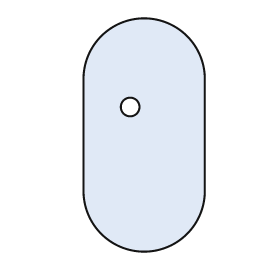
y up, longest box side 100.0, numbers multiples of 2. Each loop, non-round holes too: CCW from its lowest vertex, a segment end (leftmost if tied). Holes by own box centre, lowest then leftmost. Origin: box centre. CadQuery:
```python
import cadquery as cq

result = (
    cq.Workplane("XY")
    .moveTo(-26.0, -24.0)
    .threePointArc((0.0, -50.0), (26.0, -24.0))
    .lineTo(26.0, 24.0)
    .threePointArc((0.0, 50.0), (-26.0, 24.0))
    .close()
    .moveTo(-6.0, 12.0)
    .circle(4.0)
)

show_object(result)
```